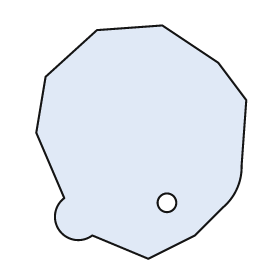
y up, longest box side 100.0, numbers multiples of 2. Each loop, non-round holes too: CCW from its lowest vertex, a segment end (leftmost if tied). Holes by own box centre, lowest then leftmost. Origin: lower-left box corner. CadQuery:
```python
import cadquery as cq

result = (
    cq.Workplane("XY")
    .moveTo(48.0, 0.0)
    .lineTo(68.0, 10.0)
    .lineTo(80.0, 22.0)
    .threePointArc((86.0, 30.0), (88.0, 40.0))
    .lineTo(90.0, 68.0)
    .lineTo(78.0, 84.0)
    .lineTo(54.0, 100.0)
    .lineTo(26.0, 98.0)
    .lineTo(4.0, 78.0)
    .lineTo(0.0, 54.0)
    .lineTo(12.0, 26.0)
    .threePointArc((10.0, 12.0), (24.0, 10.0))
    .close()
    .moveTo(56.0, 24.0)
    .circle(4.0)
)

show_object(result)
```